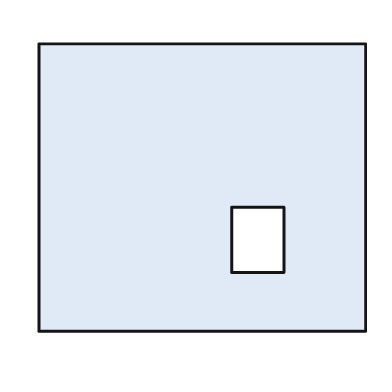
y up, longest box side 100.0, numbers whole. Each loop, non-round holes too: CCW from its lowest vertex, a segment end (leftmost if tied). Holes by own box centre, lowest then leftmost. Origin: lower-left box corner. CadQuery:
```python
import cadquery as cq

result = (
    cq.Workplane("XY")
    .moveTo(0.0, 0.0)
    .lineTo(100.0, 0.0)
    .lineTo(100.0, 88.0)
    .lineTo(0.0, 88.0)
    .close()
    .moveTo(59.0, 18.0)
    .lineTo(75.0, 18.0)
    .lineTo(75.0, 38.0)
    .lineTo(59.0, 38.0)
    .close()
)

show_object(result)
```